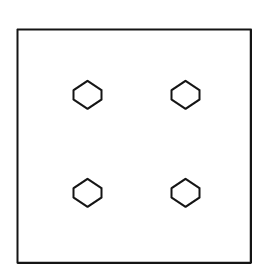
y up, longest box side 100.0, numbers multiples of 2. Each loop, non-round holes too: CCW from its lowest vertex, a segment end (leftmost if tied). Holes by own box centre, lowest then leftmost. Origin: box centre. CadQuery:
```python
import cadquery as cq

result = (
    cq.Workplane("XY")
    .moveTo(-50.0, -50.0)
    .lineTo(50.0, -50.0)
    .lineTo(50.0, 50.0)
    .lineTo(-50.0, 50.0)
    .close()
    .moveTo(-20.0, -26.0)
    .lineTo(-14.0, -22.0)
    .lineTo(-14.0, -18.0)
    .lineTo(-20.0, -14.0)
    .lineTo(-26.0, -18.0)
    .lineTo(-26.0, -22.0)
    .close()
    .moveTo(22.0, -26.0)
    .lineTo(28.0, -22.0)
    .lineTo(28.0, -18.0)
    .lineTo(22.0, -14.0)
    .lineTo(16.0, -18.0)
    .lineTo(16.0, -22.0)
    .close()
    .moveTo(-20.0, 16.0)
    .lineTo(-14.0, 20.0)
    .lineTo(-14.0, 24.0)
    .lineTo(-20.0, 28.0)
    .lineTo(-26.0, 24.0)
    .lineTo(-26.0, 20.0)
    .close()
    .moveTo(22.0, 16.0)
    .lineTo(28.0, 20.0)
    .lineTo(28.0, 24.0)
    .lineTo(22.0, 28.0)
    .lineTo(16.0, 24.0)
    .lineTo(16.0, 20.0)
    .close()
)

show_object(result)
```